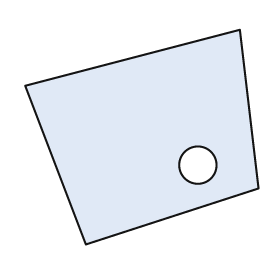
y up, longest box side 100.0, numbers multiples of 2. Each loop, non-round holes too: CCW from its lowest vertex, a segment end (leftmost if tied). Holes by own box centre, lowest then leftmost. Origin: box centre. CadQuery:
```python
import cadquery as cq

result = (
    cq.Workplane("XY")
    .moveTo(-24.0, -46.0)
    .lineTo(50.0, -22.0)
    .lineTo(42.0, 46.0)
    .lineTo(-50.0, 22.0)
    .close()
    .moveTo(24.0, -12.0)
    .circle(8.0)
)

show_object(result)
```